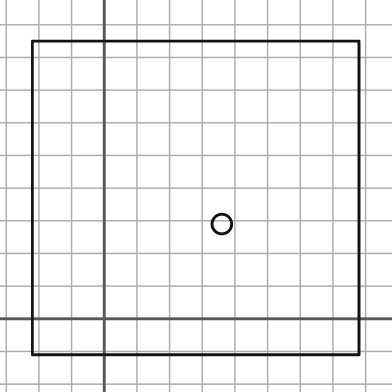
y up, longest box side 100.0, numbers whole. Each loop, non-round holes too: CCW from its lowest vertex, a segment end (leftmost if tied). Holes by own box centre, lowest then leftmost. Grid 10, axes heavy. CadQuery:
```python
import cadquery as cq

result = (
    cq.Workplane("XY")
    .moveTo(-22.0, -11.0)
    .lineTo(78.0, -11.0)
    .lineTo(78.0, 85.0)
    .lineTo(-22.0, 85.0)
    .close()
    .moveTo(36.0, 29.0)
    .circle(3.0)
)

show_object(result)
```